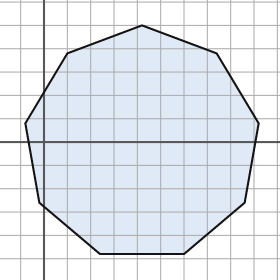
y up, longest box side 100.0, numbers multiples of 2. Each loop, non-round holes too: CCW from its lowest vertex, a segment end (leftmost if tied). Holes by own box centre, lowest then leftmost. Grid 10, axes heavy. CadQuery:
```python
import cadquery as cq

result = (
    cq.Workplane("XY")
    .moveTo(24.0, -48.0)
    .lineTo(60.0, -48.0)
    .lineTo(86.0, -26.0)
    .lineTo(92.0, 8.0)
    .lineTo(74.0, 38.0)
    .lineTo(42.0, 50.0)
    .lineTo(10.0, 38.0)
    .lineTo(-8.0, 8.0)
    .lineTo(-2.0, -26.0)
    .close()
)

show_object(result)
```